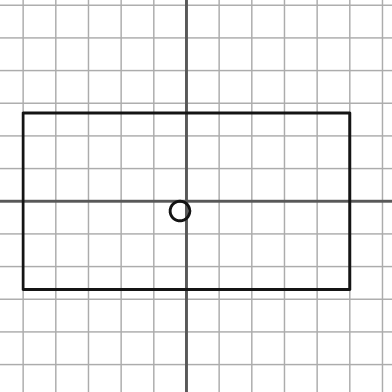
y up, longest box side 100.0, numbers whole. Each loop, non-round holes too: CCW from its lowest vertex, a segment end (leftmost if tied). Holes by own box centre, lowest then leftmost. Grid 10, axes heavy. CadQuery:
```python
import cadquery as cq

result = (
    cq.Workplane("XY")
    .moveTo(-50.0, -27.0)
    .lineTo(50.0, -27.0)
    .lineTo(50.0, 27.0)
    .lineTo(-50.0, 27.0)
    .close()
    .moveTo(-2.0, -3.0)
    .circle(3.0)
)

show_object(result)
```